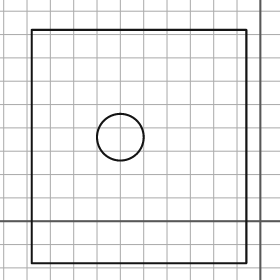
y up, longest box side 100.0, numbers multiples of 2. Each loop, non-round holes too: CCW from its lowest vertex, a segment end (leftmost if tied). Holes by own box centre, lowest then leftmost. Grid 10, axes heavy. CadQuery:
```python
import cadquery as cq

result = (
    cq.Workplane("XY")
    .moveTo(-98.0, -18.0)
    .lineTo(-6.0, -18.0)
    .lineTo(-6.0, 82.0)
    .lineTo(-98.0, 82.0)
    .close()
    .moveTo(-60.0, 36.0)
    .circle(10.0)
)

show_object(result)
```